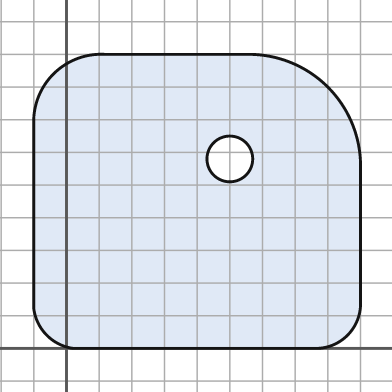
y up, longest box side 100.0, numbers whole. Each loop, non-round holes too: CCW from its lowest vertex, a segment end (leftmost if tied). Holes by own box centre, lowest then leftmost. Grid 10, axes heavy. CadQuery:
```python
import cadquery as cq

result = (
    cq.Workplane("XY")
    .moveTo(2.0, 0.0)
    .lineTo(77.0, 0.0)
    .threePointArc((86.0, 4.0), (90.0, 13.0))
    .lineTo(90.0, 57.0)
    .threePointArc((80.0, 80.0), (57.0, 90.0))
    .lineTo(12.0, 90.0)
    .threePointArc((-4.0, 84.0), (-10.0, 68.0))
    .lineTo(-10.0, 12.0)
    .threePointArc((-6.0, 4.0), (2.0, 0.0))
    .close()
    .moveTo(50.0, 58.0)
    .circle(7.0)
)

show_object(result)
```